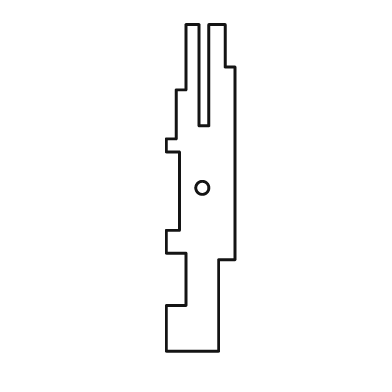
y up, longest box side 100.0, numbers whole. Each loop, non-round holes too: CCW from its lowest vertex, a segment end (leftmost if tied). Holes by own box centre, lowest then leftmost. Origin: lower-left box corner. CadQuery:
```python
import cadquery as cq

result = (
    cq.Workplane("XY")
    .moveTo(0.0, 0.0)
    .lineTo(16.0, 0.0)
    .lineTo(16.0, 28.0)
    .lineTo(21.0, 28.0)
    .lineTo(21.0, 87.0)
    .lineTo(18.0, 87.0)
    .lineTo(18.0, 100.0)
    .lineTo(13.0, 100.0)
    .lineTo(13.0, 69.0)
    .lineTo(10.0, 69.0)
    .lineTo(10.0, 100.0)
    .lineTo(6.0, 100.0)
    .lineTo(6.0, 80.0)
    .lineTo(3.0, 80.0)
    .lineTo(3.0, 65.0)
    .lineTo(0.0, 65.0)
    .lineTo(0.0, 61.0)
    .lineTo(4.0, 61.0)
    .lineTo(4.0, 37.0)
    .lineTo(0.0, 37.0)
    .lineTo(0.0, 30.0)
    .lineTo(6.0, 30.0)
    .lineTo(6.0, 14.0)
    .lineTo(0.0, 14.0)
    .close()
    .moveTo(11.0, 50.0)
    .circle(2.0)
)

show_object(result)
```